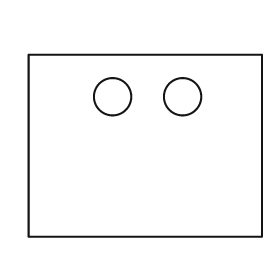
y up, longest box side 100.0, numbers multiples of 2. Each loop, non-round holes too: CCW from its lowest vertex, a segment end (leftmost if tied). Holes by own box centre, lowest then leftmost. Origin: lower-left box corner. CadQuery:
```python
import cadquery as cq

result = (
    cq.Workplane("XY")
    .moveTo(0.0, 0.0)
    .lineTo(100.0, 0.0)
    .lineTo(100.0, 78.0)
    .lineTo(0.0, 78.0)
    .close()
    .moveTo(36.0, 60.0)
    .circle(8.0)
    .moveTo(66.0, 60.0)
    .circle(8.0)
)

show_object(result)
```